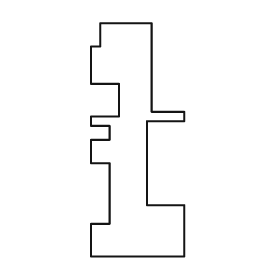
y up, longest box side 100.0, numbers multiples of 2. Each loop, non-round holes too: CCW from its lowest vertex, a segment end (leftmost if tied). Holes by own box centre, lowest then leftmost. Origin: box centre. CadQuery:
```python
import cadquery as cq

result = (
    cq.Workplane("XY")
    .moveTo(-20.0, -50.0)
    .lineTo(20.0, -50.0)
    .lineTo(20.0, -28.0)
    .lineTo(4.0, -28.0)
    .lineTo(4.0, 8.0)
    .lineTo(20.0, 8.0)
    .lineTo(20.0, 12.0)
    .lineTo(6.0, 12.0)
    .lineTo(6.0, 50.0)
    .lineTo(-16.0, 50.0)
    .lineTo(-16.0, 40.0)
    .lineTo(-20.0, 40.0)
    .lineTo(-20.0, 24.0)
    .lineTo(-8.0, 24.0)
    .lineTo(-8.0, 10.0)
    .lineTo(-20.0, 10.0)
    .lineTo(-20.0, 6.0)
    .lineTo(-12.0, 6.0)
    .lineTo(-12.0, 0.0)
    .lineTo(-20.0, 0.0)
    .lineTo(-20.0, -10.0)
    .lineTo(-12.0, -10.0)
    .lineTo(-12.0, -36.0)
    .lineTo(-20.0, -36.0)
    .close()
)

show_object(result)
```